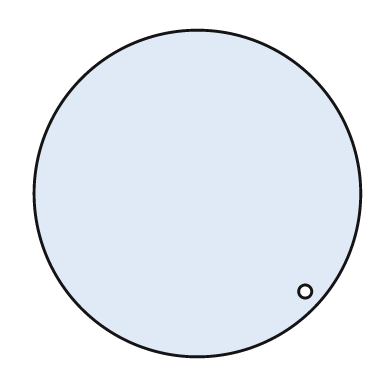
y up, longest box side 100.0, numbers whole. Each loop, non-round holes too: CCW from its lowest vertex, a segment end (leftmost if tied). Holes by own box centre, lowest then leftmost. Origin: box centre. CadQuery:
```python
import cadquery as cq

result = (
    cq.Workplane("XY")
    .moveTo(0.0, 0.0)
    .circle(50.0)
    .moveTo(33.0, -30.0)
    .circle(2.0)
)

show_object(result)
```